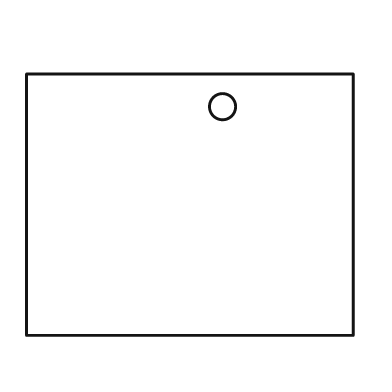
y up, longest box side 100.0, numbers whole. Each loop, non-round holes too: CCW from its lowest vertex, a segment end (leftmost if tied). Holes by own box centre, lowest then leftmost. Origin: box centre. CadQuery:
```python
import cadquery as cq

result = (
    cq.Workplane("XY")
    .moveTo(-50.0, -40.0)
    .lineTo(50.0, -40.0)
    .lineTo(50.0, 40.0)
    .lineTo(-50.0, 40.0)
    .close()
    .moveTo(10.0, 30.0)
    .circle(4.0)
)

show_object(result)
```